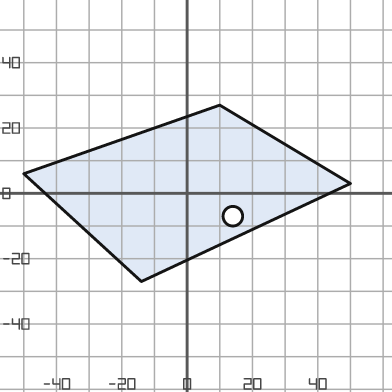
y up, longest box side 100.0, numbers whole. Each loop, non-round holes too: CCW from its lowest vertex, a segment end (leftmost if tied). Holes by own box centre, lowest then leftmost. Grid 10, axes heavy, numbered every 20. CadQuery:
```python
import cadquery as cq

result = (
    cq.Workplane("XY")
    .moveTo(-14.0, -27.0)
    .lineTo(50.0, 3.0)
    .lineTo(10.0, 27.0)
    .lineTo(-50.0, 6.0)
    .close()
    .moveTo(14.0, -7.0)
    .circle(3.0)
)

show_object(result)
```